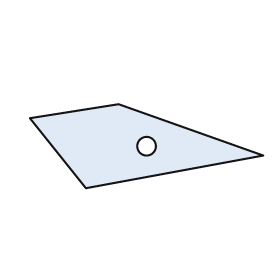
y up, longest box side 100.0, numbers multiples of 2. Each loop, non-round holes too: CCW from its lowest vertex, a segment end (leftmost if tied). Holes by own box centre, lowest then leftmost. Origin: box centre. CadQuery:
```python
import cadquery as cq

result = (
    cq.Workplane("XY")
    .moveTo(-26.0, -18.0)
    .lineTo(50.0, -4.0)
    .lineTo(-12.0, 18.0)
    .lineTo(-50.0, 12.0)
    .close()
    .moveTo(0.0, 0.0)
    .circle(4.0)
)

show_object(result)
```